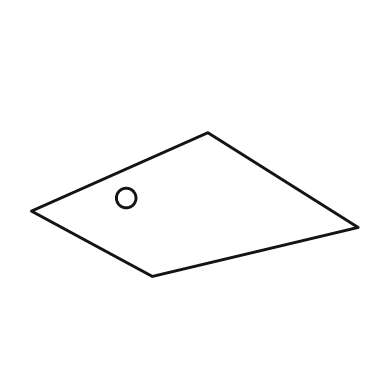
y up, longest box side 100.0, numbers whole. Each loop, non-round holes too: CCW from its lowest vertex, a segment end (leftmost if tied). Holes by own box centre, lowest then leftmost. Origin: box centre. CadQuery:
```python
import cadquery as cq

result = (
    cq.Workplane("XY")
    .moveTo(-13.0, -22.0)
    .lineTo(50.0, -7.0)
    .lineTo(4.0, 22.0)
    .lineTo(-50.0, -2.0)
    .close()
    .moveTo(-21.0, 2.0)
    .circle(3.0)
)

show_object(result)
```